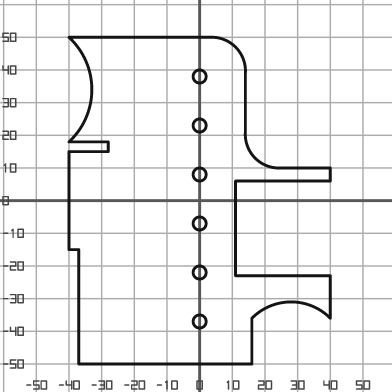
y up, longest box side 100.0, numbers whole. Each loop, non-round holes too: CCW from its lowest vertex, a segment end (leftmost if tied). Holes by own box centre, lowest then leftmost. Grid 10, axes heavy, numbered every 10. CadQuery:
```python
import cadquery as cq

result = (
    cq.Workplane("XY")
    .moveTo(-37.0, -50.0)
    .lineTo(16.0, -50.0)
    .lineTo(16.0, -36.0)
    .threePointArc((28.0, -31.0), (40.0, -36.0))
    .lineTo(40.0, -23.0)
    .lineTo(11.0, -23.0)
    .lineTo(11.0, 6.0)
    .lineTo(40.0, 6.0)
    .lineTo(40.0, 10.0)
    .lineTo(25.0, 10.0)
    .threePointArc((17.0, 13.0), (14.0, 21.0))
    .lineTo(14.0, 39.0)
    .threePointArc((11.0, 47.0), (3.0, 50.0))
    .lineTo(-40.0, 50.0)
    .threePointArc((-33.0, 34.0), (-40.0, 18.0))
    .lineTo(-28.0, 18.0)
    .lineTo(-28.0, 15.0)
    .lineTo(-40.0, 15.0)
    .lineTo(-40.0, -15.0)
    .lineTo(-37.0, -15.0)
    .close()
    .moveTo(0.0, -37.0)
    .circle(2.0)
    .moveTo(0.0, -22.0)
    .circle(2.0)
    .moveTo(0.0, -7.0)
    .circle(2.0)
    .moveTo(0.0, 8.0)
    .circle(2.0)
    .moveTo(0.0, 23.0)
    .circle(2.0)
    .moveTo(0.0, 38.0)
    .circle(2.0)
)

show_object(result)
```